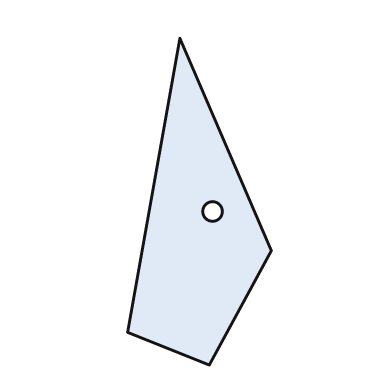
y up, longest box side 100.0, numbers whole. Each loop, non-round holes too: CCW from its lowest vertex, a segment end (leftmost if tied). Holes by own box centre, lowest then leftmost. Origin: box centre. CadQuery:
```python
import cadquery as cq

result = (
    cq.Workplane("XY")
    .moveTo(3.0, -50.0)
    .lineTo(22.0, -15.0)
    .lineTo(-6.0, 50.0)
    .lineTo(-22.0, -40.0)
    .close()
    .moveTo(4.0, -3.0)
    .circle(3.0)
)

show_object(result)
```